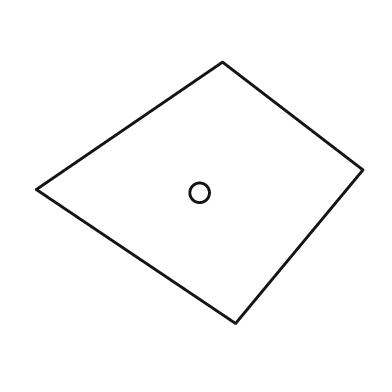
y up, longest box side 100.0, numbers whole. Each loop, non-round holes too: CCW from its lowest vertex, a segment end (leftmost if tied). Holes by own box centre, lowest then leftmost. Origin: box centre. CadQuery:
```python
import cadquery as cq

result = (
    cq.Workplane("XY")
    .moveTo(11.0, -40.0)
    .lineTo(50.0, 7.0)
    .lineTo(7.0, 40.0)
    .lineTo(-50.0, 1.0)
    .close()
    .moveTo(0.0, 0.0)
    .circle(3.0)
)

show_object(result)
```